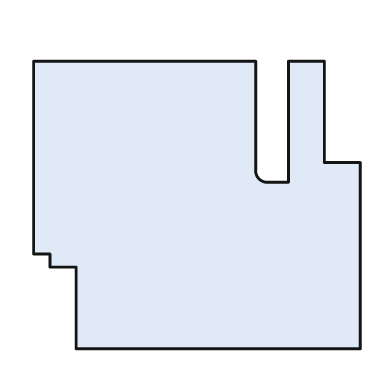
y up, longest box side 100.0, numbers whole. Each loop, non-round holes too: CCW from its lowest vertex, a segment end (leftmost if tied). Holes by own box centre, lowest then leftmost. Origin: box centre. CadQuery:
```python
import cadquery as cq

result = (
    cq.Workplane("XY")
    .moveTo(-37.0, -44.0)
    .lineTo(50.0, -44.0)
    .lineTo(50.0, 13.0)
    .lineTo(39.0, 13.0)
    .lineTo(39.0, 44.0)
    .lineTo(28.0, 44.0)
    .lineTo(28.0, 7.0)
    .lineTo(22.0, 7.0)
    .threePointArc((19.0, 8.0), (18.0, 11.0))
    .lineTo(18.0, 44.0)
    .lineTo(-50.0, 44.0)
    .lineTo(-50.0, -15.0)
    .lineTo(-45.0, -15.0)
    .lineTo(-45.0, -19.0)
    .lineTo(-37.0, -19.0)
    .close()
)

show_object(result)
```